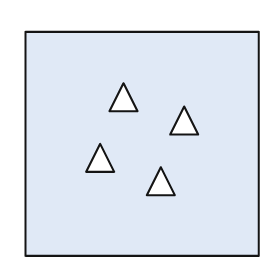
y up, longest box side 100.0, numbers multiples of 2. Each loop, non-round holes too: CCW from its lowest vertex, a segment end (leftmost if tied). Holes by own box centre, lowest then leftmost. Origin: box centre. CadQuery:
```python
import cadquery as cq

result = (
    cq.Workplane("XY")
    .moveTo(-50.0, -48.0)
    .lineTo(50.0, -48.0)
    .lineTo(50.0, 48.0)
    .lineTo(-50.0, 48.0)
    .close()
    .moveTo(2.0, -22.0)
    .lineTo(14.0, -22.0)
    .lineTo(8.0, -10.0)
    .close()
    .moveTo(-24.0, -12.0)
    .lineTo(-12.0, -12.0)
    .lineTo(-18.0, 0.0)
    .close()
    .moveTo(12.0, 4.0)
    .lineTo(24.0, 4.0)
    .lineTo(18.0, 16.0)
    .close()
    .moveTo(-14.0, 14.0)
    .lineTo(-2.0, 14.0)
    .lineTo(-8.0, 26.0)
    .close()
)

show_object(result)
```